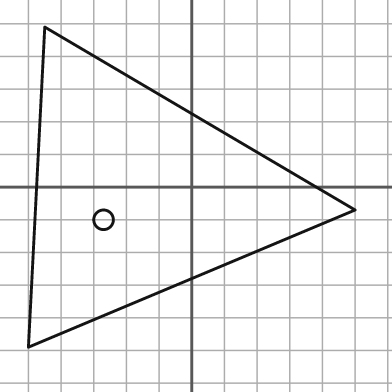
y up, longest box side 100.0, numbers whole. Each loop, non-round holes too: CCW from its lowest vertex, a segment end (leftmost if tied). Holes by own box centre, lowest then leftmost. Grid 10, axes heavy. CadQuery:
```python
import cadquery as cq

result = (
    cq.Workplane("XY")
    .moveTo(-50.0, -49.0)
    .lineTo(50.0, -7.0)
    .lineTo(-45.0, 49.0)
    .close()
    .moveTo(-27.0, -10.0)
    .circle(3.0)
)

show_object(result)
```